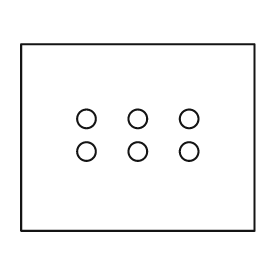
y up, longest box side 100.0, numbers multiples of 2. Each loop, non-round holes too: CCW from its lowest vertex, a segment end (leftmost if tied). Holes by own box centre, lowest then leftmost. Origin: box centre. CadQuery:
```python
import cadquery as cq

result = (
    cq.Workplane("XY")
    .moveTo(-50.0, -40.0)
    .lineTo(50.0, -40.0)
    .lineTo(50.0, 40.0)
    .lineTo(-50.0, 40.0)
    .close()
    .moveTo(-22.0, -6.0)
    .circle(4.0)
    .moveTo(0.0, -6.0)
    .circle(4.0)
    .moveTo(22.0, -6.0)
    .circle(4.0)
    .moveTo(-22.0, 8.0)
    .circle(4.0)
    .moveTo(0.0, 8.0)
    .circle(4.0)
    .moveTo(22.0, 8.0)
    .circle(4.0)
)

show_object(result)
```